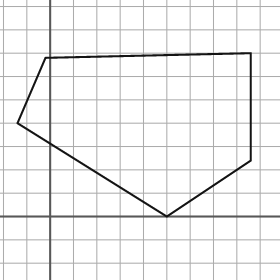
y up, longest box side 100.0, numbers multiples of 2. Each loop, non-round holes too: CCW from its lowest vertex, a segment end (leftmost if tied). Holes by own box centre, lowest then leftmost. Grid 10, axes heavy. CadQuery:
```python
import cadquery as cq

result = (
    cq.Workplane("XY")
    .moveTo(50.0, 0.0)
    .lineTo(86.0, 24.0)
    .lineTo(86.0, 70.0)
    .lineTo(-2.0, 68.0)
    .lineTo(-14.0, 40.0)
    .close()
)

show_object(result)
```